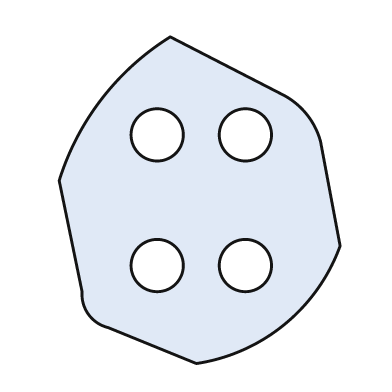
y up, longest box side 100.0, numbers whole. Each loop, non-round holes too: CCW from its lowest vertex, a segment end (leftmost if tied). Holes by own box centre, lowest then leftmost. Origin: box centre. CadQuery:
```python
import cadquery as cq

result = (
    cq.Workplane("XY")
    .moveTo(-1.0, -50.0)
    .threePointArc((26.0, -38.0), (43.0, -14.0))
    .lineTo(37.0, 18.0)
    .threePointArc((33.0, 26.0), (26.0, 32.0))
    .lineTo(-9.0, 50.0)
    .threePointArc((-30.0, 31.0), (-43.0, 6.0))
    .lineTo(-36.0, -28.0)
    .threePointArc((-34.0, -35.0), (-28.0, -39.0))
    .close()
    .moveTo(-13.0, -20.0)
    .circle(8.0)
    .moveTo(14.0, -20.0)
    .circle(8.0)
    .moveTo(-13.0, 20.0)
    .circle(8.0)
    .moveTo(14.0, 20.0)
    .circle(8.0)
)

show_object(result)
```